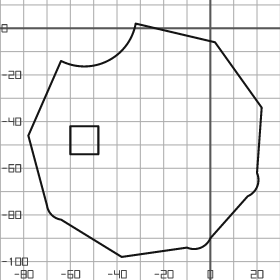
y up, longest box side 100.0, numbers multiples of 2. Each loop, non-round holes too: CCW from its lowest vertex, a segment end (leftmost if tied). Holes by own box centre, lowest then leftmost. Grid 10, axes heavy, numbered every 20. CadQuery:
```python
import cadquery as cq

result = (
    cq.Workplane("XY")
    .moveTo(-38.0, -98.0)
    .lineTo(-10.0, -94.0)
    .threePointArc((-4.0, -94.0), (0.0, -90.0))
    .lineTo(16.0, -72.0)
    .threePointArc((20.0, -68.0), (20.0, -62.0))
    .lineTo(22.0, -34.0)
    .lineTo(2.0, -6.0)
    .lineTo(-32.0, 2.0)
    .threePointArc((-44.0, -14.0), (-64.0, -14.0))
    .lineTo(-78.0, -46.0)
    .lineTo(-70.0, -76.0)
    .threePointArc((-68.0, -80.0), (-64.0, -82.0))
    .close()
    .moveTo(-60.0, -54.0)
    .lineTo(-48.0, -54.0)
    .lineTo(-48.0, -42.0)
    .lineTo(-60.0, -42.0)
    .close()
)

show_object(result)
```